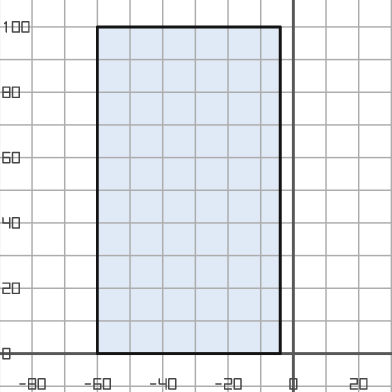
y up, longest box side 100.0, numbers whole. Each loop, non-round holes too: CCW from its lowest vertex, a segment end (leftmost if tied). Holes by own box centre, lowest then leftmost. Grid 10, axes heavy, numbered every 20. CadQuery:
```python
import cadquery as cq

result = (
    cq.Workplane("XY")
    .moveTo(-60.0, 0.0)
    .lineTo(-4.0, 0.0)
    .lineTo(-4.0, 100.0)
    .lineTo(-60.0, 100.0)
    .close()
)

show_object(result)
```